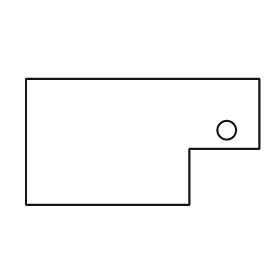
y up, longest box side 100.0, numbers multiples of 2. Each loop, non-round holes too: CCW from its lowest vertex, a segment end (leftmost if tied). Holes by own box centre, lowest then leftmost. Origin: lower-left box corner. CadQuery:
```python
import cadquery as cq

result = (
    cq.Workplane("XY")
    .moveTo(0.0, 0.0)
    .lineTo(70.0, 0.0)
    .lineTo(70.0, 24.0)
    .lineTo(100.0, 24.0)
    .lineTo(100.0, 54.0)
    .lineTo(0.0, 54.0)
    .close()
    .moveTo(86.0, 32.0)
    .circle(4.0)
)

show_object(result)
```